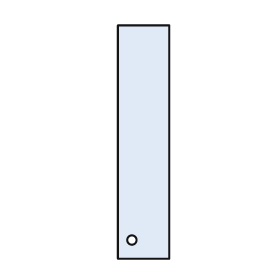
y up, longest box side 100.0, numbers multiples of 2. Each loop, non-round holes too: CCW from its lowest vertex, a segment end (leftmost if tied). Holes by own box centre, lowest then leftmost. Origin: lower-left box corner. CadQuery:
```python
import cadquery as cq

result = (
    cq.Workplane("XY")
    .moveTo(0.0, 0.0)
    .lineTo(22.0, 0.0)
    .lineTo(22.0, 100.0)
    .lineTo(0.0, 100.0)
    .close()
    .moveTo(6.0, 8.0)
    .circle(2.0)
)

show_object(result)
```